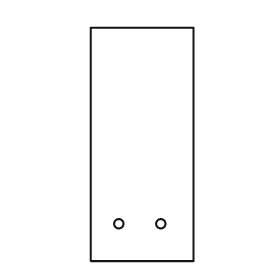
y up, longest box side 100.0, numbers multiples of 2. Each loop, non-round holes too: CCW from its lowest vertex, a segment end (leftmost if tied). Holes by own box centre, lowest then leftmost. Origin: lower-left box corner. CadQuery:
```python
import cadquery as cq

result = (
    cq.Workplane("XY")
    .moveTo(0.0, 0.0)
    .lineTo(44.0, 0.0)
    .lineTo(44.0, 100.0)
    .lineTo(0.0, 100.0)
    .close()
    .moveTo(12.0, 16.0)
    .circle(2.0)
    .moveTo(30.0, 16.0)
    .circle(2.0)
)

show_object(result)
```